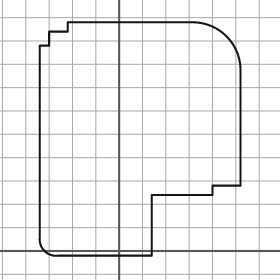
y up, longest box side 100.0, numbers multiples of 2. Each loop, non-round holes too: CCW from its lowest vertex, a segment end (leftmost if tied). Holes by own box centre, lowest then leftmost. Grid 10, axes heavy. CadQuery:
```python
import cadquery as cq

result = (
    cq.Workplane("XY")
    .moveTo(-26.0, -2.0)
    .lineTo(14.0, -2.0)
    .lineTo(14.0, 24.0)
    .lineTo(40.0, 24.0)
    .lineTo(40.0, 28.0)
    .lineTo(52.0, 28.0)
    .lineTo(52.0, 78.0)
    .threePointArc((46.0, 92.0), (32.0, 98.0))
    .lineTo(-22.0, 98.0)
    .lineTo(-22.0, 94.0)
    .lineTo(-30.0, 94.0)
    .lineTo(-30.0, 88.0)
    .lineTo(-34.0, 88.0)
    .lineTo(-34.0, 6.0)
    .threePointArc((-32.0, 0.0), (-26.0, -2.0))
    .close()
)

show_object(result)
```